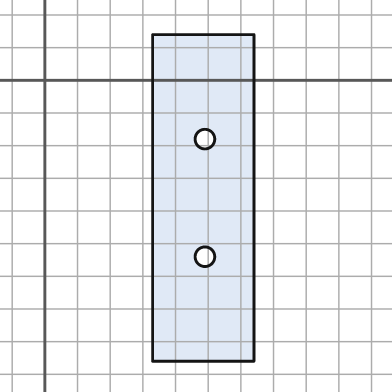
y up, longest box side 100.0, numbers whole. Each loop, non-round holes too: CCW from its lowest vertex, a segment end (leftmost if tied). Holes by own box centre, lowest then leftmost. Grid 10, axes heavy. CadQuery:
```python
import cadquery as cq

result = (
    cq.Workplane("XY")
    .moveTo(33.0, -86.0)
    .lineTo(64.0, -86.0)
    .lineTo(64.0, 14.0)
    .lineTo(33.0, 14.0)
    .close()
    .moveTo(49.0, -54.0)
    .circle(3.0)
    .moveTo(49.0, -18.0)
    .circle(3.0)
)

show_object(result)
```